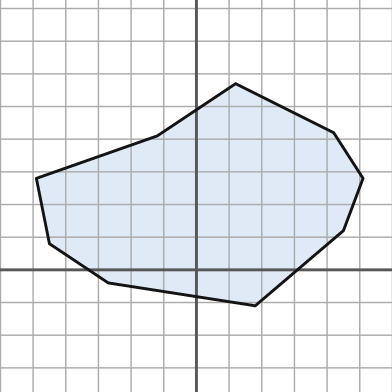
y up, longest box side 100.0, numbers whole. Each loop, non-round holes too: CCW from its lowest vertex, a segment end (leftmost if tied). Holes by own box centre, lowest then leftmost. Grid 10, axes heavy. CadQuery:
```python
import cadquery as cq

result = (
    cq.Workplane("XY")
    .moveTo(18.0, -11.0)
    .lineTo(45.0, 12.0)
    .lineTo(51.0, 28.0)
    .lineTo(42.0, 42.0)
    .lineTo(12.0, 57.0)
    .lineTo(-12.0, 41.0)
    .lineTo(-49.0, 28.0)
    .lineTo(-45.0, 8.0)
    .lineTo(-27.0, -4.0)
    .close()
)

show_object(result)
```